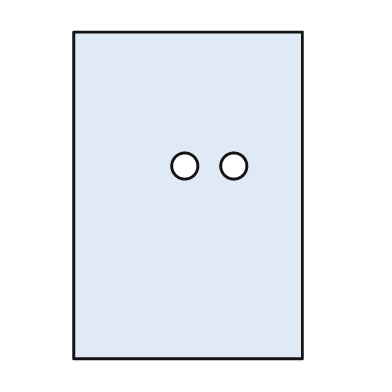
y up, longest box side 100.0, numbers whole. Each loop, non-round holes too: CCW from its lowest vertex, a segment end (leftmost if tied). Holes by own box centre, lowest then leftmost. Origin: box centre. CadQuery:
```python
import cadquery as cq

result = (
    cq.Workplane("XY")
    .moveTo(-35.0, -50.0)
    .lineTo(35.0, -50.0)
    .lineTo(35.0, 50.0)
    .lineTo(-35.0, 50.0)
    .close()
    .moveTo(-1.0, 9.0)
    .circle(4.0)
    .moveTo(14.0, 9.0)
    .circle(4.0)
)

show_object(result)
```